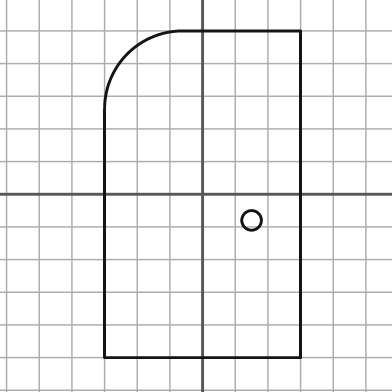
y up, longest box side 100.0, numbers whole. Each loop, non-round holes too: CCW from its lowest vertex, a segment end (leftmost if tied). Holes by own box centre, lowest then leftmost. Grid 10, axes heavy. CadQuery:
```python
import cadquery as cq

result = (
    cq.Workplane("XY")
    .moveTo(-30.0, -50.0)
    .lineTo(30.0, -50.0)
    .lineTo(30.0, 50.0)
    .lineTo(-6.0, 50.0)
    .threePointArc((-23.0, 43.0), (-30.0, 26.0))
    .close()
    .moveTo(15.0, -8.0)
    .circle(3.0)
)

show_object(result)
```